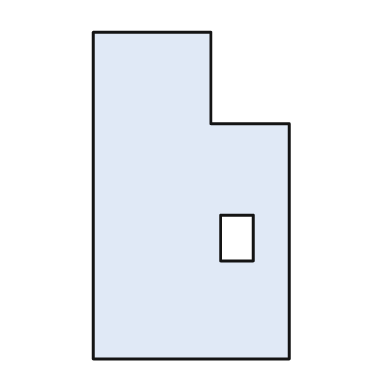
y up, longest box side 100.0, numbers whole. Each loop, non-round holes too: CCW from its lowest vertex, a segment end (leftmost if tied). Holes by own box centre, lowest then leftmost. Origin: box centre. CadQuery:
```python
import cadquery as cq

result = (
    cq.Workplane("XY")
    .moveTo(-30.0, -50.0)
    .lineTo(30.0, -50.0)
    .lineTo(30.0, 22.0)
    .lineTo(6.0, 22.0)
    .lineTo(6.0, 50.0)
    .lineTo(-30.0, 50.0)
    .close()
    .moveTo(9.0, -20.0)
    .lineTo(19.0, -20.0)
    .lineTo(19.0, -6.0)
    .lineTo(9.0, -6.0)
    .close()
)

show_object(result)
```